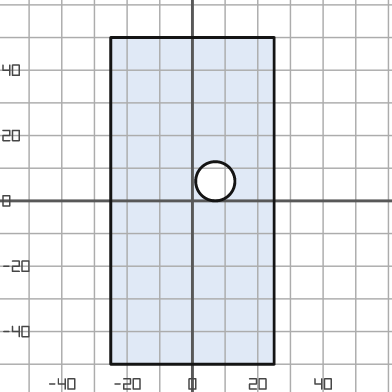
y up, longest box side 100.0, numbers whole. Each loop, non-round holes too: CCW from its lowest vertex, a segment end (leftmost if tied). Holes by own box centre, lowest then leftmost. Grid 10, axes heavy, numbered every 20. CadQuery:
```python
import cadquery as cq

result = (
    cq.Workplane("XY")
    .moveTo(-25.0, -50.0)
    .lineTo(25.0, -50.0)
    .lineTo(25.0, 50.0)
    .lineTo(-25.0, 50.0)
    .close()
    .moveTo(7.0, 6.0)
    .circle(6.0)
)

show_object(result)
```